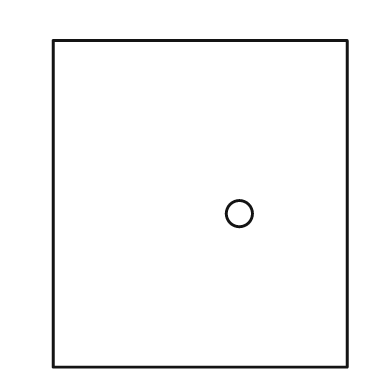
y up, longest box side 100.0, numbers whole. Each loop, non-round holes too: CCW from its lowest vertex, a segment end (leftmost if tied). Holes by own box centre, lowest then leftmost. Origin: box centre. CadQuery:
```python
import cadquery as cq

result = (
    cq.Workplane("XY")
    .moveTo(-45.0, -50.0)
    .lineTo(45.0, -50.0)
    .lineTo(45.0, 50.0)
    .lineTo(-45.0, 50.0)
    .close()
    .moveTo(12.0, -3.0)
    .circle(4.0)
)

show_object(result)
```